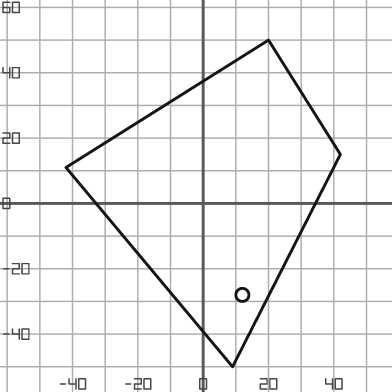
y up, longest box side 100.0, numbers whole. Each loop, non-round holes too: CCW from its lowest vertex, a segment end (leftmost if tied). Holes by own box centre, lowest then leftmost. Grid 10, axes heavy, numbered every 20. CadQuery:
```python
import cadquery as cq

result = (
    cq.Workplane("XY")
    .moveTo(9.0, -50.0)
    .lineTo(42.0, 15.0)
    .lineTo(20.0, 50.0)
    .lineTo(-42.0, 11.0)
    .close()
    .moveTo(12.0, -28.0)
    .circle(2.0)
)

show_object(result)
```